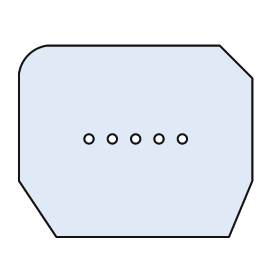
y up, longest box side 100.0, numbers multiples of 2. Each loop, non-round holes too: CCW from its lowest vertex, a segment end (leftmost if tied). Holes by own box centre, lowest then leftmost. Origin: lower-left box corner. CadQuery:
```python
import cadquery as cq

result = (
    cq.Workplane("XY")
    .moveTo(16.0, 0.0)
    .lineTo(90.0, 0.0)
    .lineTo(100.0, 24.0)
    .lineTo(100.0, 68.0)
    .lineTo(86.0, 82.0)
    .lineTo(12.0, 82.0)
    .threePointArc((4.0, 78.0), (0.0, 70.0))
    .lineTo(0.0, 24.0)
    .close()
    .moveTo(30.0, 42.0)
    .circle(2.0)
    .moveTo(40.0, 42.0)
    .circle(2.0)
    .moveTo(50.0, 42.0)
    .circle(2.0)
    .moveTo(60.0, 42.0)
    .circle(2.0)
    .moveTo(70.0, 42.0)
    .circle(2.0)
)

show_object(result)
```